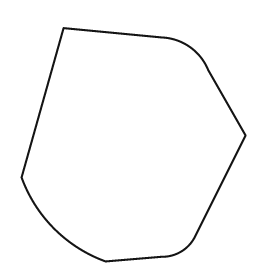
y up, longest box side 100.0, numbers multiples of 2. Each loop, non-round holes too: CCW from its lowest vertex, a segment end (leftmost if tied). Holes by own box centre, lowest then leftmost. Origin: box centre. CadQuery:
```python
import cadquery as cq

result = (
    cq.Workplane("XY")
    .moveTo(-12.0, -50.0)
    .lineTo(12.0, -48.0)
    .threePointArc((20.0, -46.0), (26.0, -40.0))
    .lineTo(48.0, 4.0)
    .lineTo(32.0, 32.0)
    .threePointArc((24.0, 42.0), (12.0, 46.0))
    .lineTo(-30.0, 50.0)
    .lineTo(-48.0, -14.0)
    .threePointArc((-34.0, -36.0), (-12.0, -50.0))
    .close()
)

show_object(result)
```